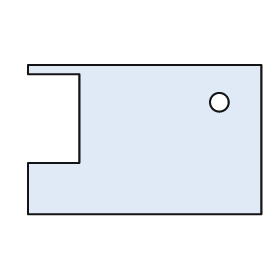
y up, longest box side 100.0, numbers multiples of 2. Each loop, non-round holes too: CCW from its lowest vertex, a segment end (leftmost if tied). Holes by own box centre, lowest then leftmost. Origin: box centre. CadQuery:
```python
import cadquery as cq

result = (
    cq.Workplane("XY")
    .moveTo(-50.0, -32.0)
    .lineTo(50.0, -32.0)
    .lineTo(50.0, 32.0)
    .lineTo(-50.0, 32.0)
    .lineTo(-50.0, 28.0)
    .lineTo(-28.0, 28.0)
    .lineTo(-28.0, -10.0)
    .lineTo(-50.0, -10.0)
    .close()
    .moveTo(32.0, 16.0)
    .circle(4.0)
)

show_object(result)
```